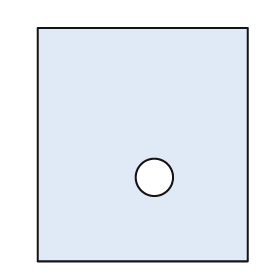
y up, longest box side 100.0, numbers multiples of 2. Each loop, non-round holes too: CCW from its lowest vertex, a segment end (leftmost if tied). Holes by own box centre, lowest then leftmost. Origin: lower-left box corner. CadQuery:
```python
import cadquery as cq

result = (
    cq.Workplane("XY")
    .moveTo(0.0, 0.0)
    .lineTo(90.0, 0.0)
    .lineTo(90.0, 100.0)
    .lineTo(0.0, 100.0)
    .close()
    .moveTo(50.0, 36.0)
    .circle(8.0)
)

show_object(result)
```